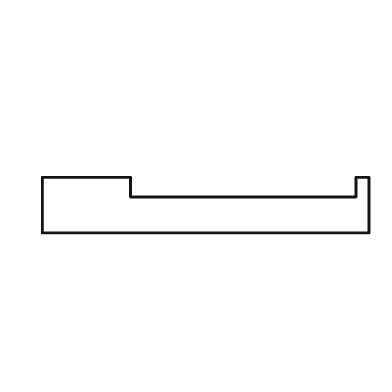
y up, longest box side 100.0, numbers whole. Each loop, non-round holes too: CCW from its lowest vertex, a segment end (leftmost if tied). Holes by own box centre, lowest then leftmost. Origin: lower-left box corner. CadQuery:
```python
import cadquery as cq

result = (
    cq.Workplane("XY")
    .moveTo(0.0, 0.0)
    .lineTo(100.0, 0.0)
    .lineTo(100.0, 17.0)
    .lineTo(96.0, 17.0)
    .lineTo(96.0, 11.0)
    .lineTo(27.0, 11.0)
    .lineTo(27.0, 17.0)
    .lineTo(0.0, 17.0)
    .close()
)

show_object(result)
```